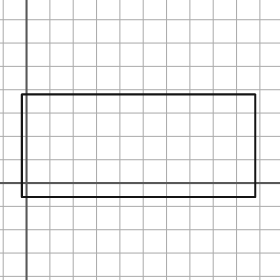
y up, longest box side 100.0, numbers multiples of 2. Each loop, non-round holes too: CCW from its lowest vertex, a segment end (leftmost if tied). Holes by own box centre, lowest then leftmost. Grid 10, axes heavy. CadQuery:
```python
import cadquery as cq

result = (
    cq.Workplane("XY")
    .moveTo(-2.0, -6.0)
    .lineTo(98.0, -6.0)
    .lineTo(98.0, 38.0)
    .lineTo(-2.0, 38.0)
    .close()
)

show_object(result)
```